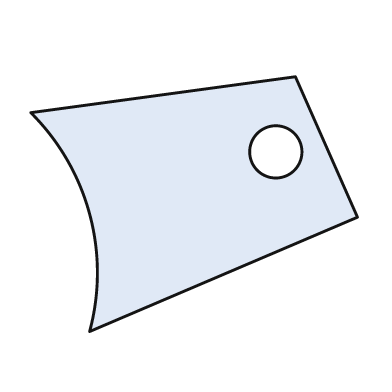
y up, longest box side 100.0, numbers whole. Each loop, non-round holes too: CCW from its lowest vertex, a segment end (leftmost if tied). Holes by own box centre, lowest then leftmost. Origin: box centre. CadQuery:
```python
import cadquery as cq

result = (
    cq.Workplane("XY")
    .moveTo(-32.0, -39.0)
    .lineTo(50.0, -4.0)
    .lineTo(31.0, 39.0)
    .lineTo(-50.0, 28.0)
    .threePointArc((-32.0, -3.0), (-32.0, -39.0))
    .close()
    .moveTo(25.0, 16.0)
    .circle(8.0)
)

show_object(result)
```